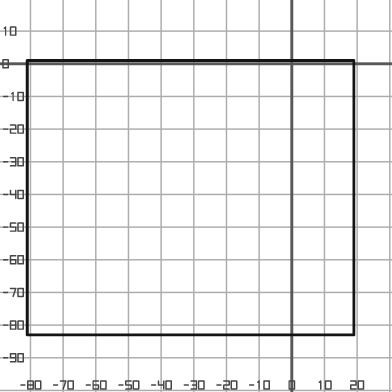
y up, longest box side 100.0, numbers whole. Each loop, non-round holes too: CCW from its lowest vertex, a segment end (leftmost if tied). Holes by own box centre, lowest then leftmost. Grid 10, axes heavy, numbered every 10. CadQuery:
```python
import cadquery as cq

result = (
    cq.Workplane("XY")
    .moveTo(-81.0, -83.0)
    .lineTo(19.0, -83.0)
    .lineTo(19.0, 1.0)
    .lineTo(-81.0, 1.0)
    .close()
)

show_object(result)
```